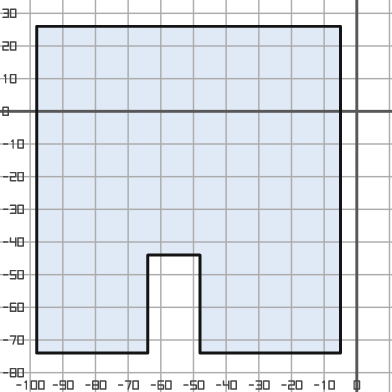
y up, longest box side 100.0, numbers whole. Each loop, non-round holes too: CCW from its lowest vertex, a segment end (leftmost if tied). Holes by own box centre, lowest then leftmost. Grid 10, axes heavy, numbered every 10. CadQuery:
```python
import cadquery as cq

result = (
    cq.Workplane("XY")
    .moveTo(-98.0, -74.0)
    .lineTo(-64.0, -74.0)
    .lineTo(-64.0, -44.0)
    .lineTo(-48.0, -44.0)
    .lineTo(-48.0, -74.0)
    .lineTo(-5.0, -74.0)
    .lineTo(-5.0, 26.0)
    .lineTo(-98.0, 26.0)
    .close()
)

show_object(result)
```